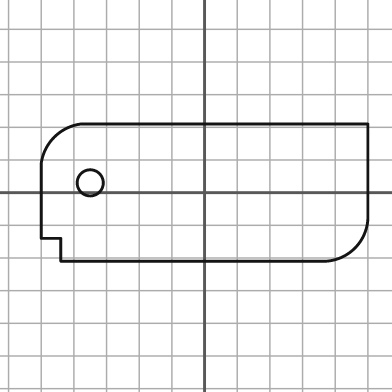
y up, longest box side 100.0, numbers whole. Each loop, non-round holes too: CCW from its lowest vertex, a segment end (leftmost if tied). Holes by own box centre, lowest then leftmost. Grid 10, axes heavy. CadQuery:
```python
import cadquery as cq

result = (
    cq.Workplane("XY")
    .moveTo(-44.0, -21.0)
    .lineTo(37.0, -21.0)
    .threePointArc((46.0, -17.0), (50.0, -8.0))
    .lineTo(50.0, 21.0)
    .lineTo(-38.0, 21.0)
    .threePointArc((-46.0, 17.0), (-50.0, 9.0))
    .lineTo(-50.0, -14.0)
    .lineTo(-44.0, -14.0)
    .close()
    .moveTo(-35.0, 3.0)
    .circle(4.0)
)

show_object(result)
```